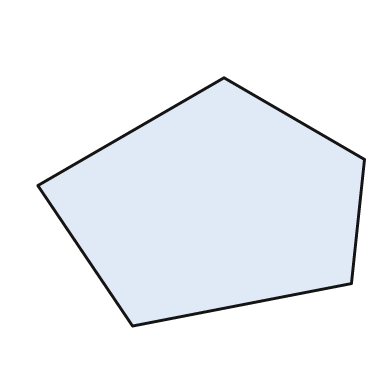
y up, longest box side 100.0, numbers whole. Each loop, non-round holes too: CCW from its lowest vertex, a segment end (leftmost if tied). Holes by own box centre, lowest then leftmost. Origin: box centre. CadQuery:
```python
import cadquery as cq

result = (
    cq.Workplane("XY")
    .moveTo(-21.0, -38.0)
    .lineTo(46.0, -25.0)
    .lineTo(50.0, 13.0)
    .lineTo(7.0, 38.0)
    .lineTo(-50.0, 5.0)
    .close()
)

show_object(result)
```